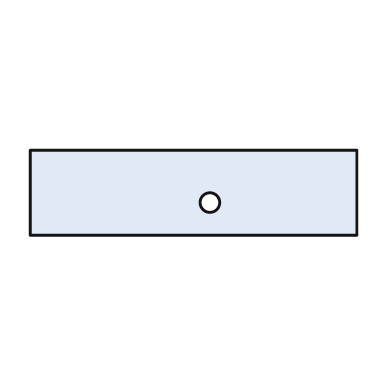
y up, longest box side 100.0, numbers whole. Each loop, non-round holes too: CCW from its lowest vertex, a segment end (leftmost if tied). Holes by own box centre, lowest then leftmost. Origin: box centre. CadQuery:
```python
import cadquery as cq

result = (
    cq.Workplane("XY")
    .moveTo(-50.0, -13.0)
    .lineTo(50.0, -13.0)
    .lineTo(50.0, 13.0)
    .lineTo(-50.0, 13.0)
    .close()
    .moveTo(5.0, -3.0)
    .circle(3.0)
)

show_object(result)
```